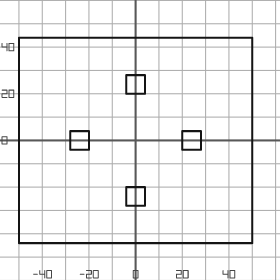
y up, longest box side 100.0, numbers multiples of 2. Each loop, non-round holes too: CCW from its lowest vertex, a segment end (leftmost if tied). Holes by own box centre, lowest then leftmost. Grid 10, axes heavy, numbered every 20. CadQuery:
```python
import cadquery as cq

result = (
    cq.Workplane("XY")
    .moveTo(-50.0, -44.0)
    .lineTo(50.0, -44.0)
    .lineTo(50.0, 44.0)
    .lineTo(-50.0, 44.0)
    .close()
    .moveTo(-4.0, -28.0)
    .lineTo(4.0, -28.0)
    .lineTo(4.0, -20.0)
    .lineTo(-4.0, -20.0)
    .close()
    .moveTo(-28.0, -4.0)
    .lineTo(-20.0, -4.0)
    .lineTo(-20.0, 4.0)
    .lineTo(-28.0, 4.0)
    .close()
    .moveTo(20.0, -4.0)
    .lineTo(28.0, -4.0)
    .lineTo(28.0, 4.0)
    .lineTo(20.0, 4.0)
    .close()
    .moveTo(-4.0, 20.0)
    .lineTo(4.0, 20.0)
    .lineTo(4.0, 28.0)
    .lineTo(-4.0, 28.0)
    .close()
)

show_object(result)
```